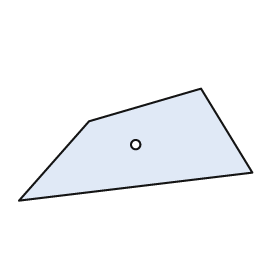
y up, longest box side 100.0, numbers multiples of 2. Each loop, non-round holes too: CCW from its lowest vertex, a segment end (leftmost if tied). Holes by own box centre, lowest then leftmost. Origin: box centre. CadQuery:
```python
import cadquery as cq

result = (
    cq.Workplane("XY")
    .moveTo(-50.0, -24.0)
    .lineTo(50.0, -12.0)
    .lineTo(28.0, 24.0)
    .lineTo(-20.0, 10.0)
    .close()
    .moveTo(0.0, 0.0)
    .circle(2.0)
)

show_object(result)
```